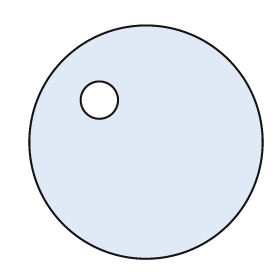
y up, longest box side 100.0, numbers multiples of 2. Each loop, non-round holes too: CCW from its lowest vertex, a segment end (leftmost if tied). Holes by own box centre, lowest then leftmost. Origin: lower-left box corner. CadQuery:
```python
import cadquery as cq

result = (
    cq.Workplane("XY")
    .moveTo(50.0, 50.0)
    .circle(50.0)
    .moveTo(30.0, 68.0)
    .circle(8.0)
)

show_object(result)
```